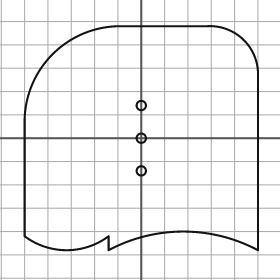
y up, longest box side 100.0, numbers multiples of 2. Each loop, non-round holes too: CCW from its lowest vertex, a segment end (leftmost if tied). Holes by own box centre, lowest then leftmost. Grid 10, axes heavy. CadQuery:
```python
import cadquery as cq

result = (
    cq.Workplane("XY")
    .moveTo(-14.0, -48.0)
    .threePointArc((18.0, -40.0), (50.0, -48.0))
    .lineTo(50.0, 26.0)
    .threePointArc((44.0, 42.0), (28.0, 48.0))
    .lineTo(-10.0, 48.0)
    .threePointArc((-38.0, 36.0), (-50.0, 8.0))
    .lineTo(-50.0, -42.0)
    .threePointArc((-32.0, -48.0), (-14.0, -42.0))
    .close()
    .moveTo(0.0, -14.0)
    .circle(2.0)
    .moveTo(0.0, 0.0)
    .circle(2.0)
    .moveTo(0.0, 14.0)
    .circle(2.0)
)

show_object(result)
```